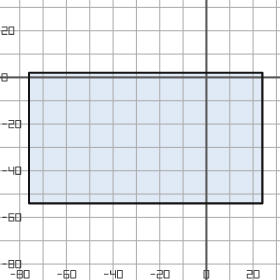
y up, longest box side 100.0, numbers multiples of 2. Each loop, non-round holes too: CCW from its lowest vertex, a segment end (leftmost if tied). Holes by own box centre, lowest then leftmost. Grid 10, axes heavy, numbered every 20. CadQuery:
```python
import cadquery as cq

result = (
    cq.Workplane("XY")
    .moveTo(-76.0, -54.0)
    .lineTo(24.0, -54.0)
    .lineTo(24.0, 2.0)
    .lineTo(-76.0, 2.0)
    .close()
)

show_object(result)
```